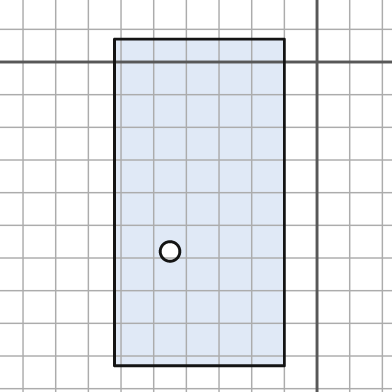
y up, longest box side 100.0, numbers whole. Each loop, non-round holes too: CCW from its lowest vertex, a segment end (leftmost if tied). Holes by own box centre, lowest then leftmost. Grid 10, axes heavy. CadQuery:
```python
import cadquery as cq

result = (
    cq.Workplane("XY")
    .moveTo(-62.0, -93.0)
    .lineTo(-10.0, -93.0)
    .lineTo(-10.0, 7.0)
    .lineTo(-62.0, 7.0)
    .close()
    .moveTo(-45.0, -58.0)
    .circle(3.0)
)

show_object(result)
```